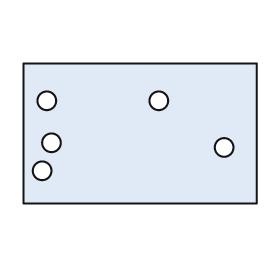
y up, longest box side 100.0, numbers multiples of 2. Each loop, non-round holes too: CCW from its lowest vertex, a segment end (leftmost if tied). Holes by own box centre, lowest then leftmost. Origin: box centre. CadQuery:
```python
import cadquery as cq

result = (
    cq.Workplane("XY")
    .moveTo(-50.0, -30.0)
    .lineTo(50.0, -30.0)
    .lineTo(50.0, 30.0)
    .lineTo(-50.0, 30.0)
    .close()
    .moveTo(-42.0, -16.0)
    .circle(4.0)
    .moveTo(36.0, -6.0)
    .circle(4.0)
    .moveTo(-38.0, -4.0)
    .circle(4.0)
    .moveTo(-40.0, 14.0)
    .circle(4.0)
    .moveTo(8.0, 14.0)
    .circle(4.0)
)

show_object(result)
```